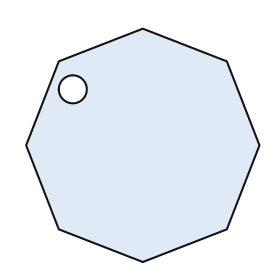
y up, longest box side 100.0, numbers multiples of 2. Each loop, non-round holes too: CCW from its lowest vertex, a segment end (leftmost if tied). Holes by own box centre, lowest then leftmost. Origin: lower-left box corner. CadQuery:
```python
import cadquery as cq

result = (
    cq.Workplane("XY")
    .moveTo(50.0, 0.0)
    .lineTo(86.0, 14.0)
    .lineTo(100.0, 50.0)
    .lineTo(86.0, 86.0)
    .lineTo(50.0, 100.0)
    .lineTo(14.0, 86.0)
    .lineTo(0.0, 50.0)
    .lineTo(14.0, 14.0)
    .close()
    .moveTo(20.0, 74.0)
    .circle(6.0)
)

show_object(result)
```